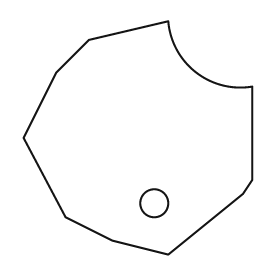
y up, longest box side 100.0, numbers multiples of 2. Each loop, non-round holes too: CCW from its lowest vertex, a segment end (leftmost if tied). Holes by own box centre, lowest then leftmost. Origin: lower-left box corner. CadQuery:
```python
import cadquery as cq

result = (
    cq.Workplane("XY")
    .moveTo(62.0, 0.0)
    .lineTo(94.0, 26.0)
    .lineTo(98.0, 32.0)
    .lineTo(98.0, 72.0)
    .threePointArc((74.0, 78.0), (62.0, 100.0))
    .lineTo(28.0, 92.0)
    .lineTo(14.0, 78.0)
    .lineTo(0.0, 50.0)
    .lineTo(18.0, 16.0)
    .lineTo(38.0, 6.0)
    .close()
    .moveTo(56.0, 22.0)
    .circle(6.0)
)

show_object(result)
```